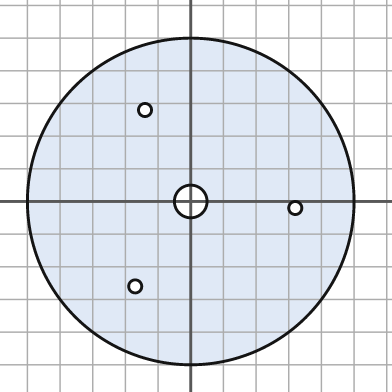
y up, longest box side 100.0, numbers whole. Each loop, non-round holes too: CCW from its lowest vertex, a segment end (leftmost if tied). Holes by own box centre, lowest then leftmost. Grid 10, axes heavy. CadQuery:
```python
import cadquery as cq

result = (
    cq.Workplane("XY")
    .moveTo(0.0, 0.0)
    .circle(50.0)
    .moveTo(-17.0, -26.0)
    .circle(2.0)
    .moveTo(32.0, -2.0)
    .circle(2.0)
    .moveTo(0.0, 0.0)
    .circle(5.0)
    .moveTo(-14.0, 28.0)
    .circle(2.0)
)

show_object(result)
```